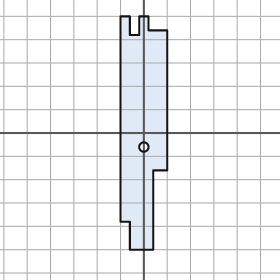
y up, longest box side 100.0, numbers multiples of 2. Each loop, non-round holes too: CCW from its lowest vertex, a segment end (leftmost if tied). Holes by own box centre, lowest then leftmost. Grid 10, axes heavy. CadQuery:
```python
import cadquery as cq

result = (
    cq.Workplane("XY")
    .moveTo(-6.0, -50.0)
    .lineTo(4.0, -50.0)
    .lineTo(4.0, -16.0)
    .lineTo(10.0, -16.0)
    .lineTo(10.0, 44.0)
    .lineTo(2.0, 44.0)
    .lineTo(2.0, 50.0)
    .lineTo(-2.0, 50.0)
    .lineTo(-2.0, 42.0)
    .lineTo(-6.0, 42.0)
    .lineTo(-6.0, 50.0)
    .lineTo(-10.0, 50.0)
    .lineTo(-10.0, -38.0)
    .lineTo(-6.0, -38.0)
    .close()
    .moveTo(0.0, -6.0)
    .circle(2.0)
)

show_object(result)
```